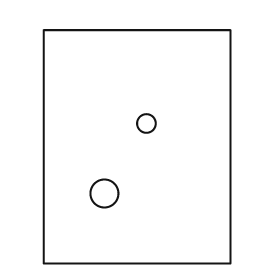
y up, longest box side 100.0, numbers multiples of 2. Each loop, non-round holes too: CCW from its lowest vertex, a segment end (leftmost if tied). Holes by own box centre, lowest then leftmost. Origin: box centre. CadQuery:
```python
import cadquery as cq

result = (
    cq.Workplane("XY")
    .moveTo(-40.0, -50.0)
    .lineTo(40.0, -50.0)
    .lineTo(40.0, 50.0)
    .lineTo(-40.0, 50.0)
    .close()
    .moveTo(-14.0, -20.0)
    .circle(6.0)
    .moveTo(4.0, 10.0)
    .circle(4.0)
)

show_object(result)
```